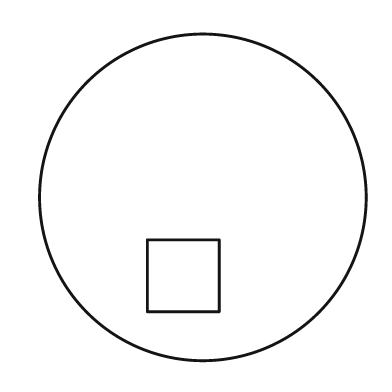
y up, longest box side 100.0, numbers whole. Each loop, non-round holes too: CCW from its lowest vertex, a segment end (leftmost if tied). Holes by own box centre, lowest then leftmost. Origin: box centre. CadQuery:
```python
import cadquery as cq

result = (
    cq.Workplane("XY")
    .moveTo(0.0, 0.0)
    .circle(50.0)
    .moveTo(-17.0, -35.0)
    .lineTo(5.0, -35.0)
    .lineTo(5.0, -13.0)
    .lineTo(-17.0, -13.0)
    .close()
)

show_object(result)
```